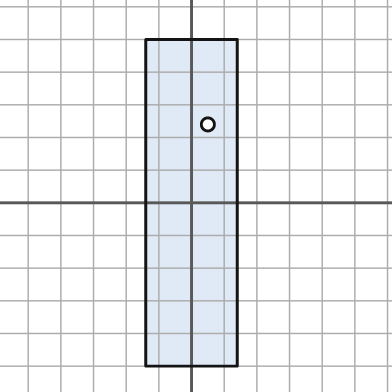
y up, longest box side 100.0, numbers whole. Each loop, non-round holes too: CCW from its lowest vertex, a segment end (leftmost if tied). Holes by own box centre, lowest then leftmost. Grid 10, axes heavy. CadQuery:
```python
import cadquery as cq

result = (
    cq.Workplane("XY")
    .moveTo(-14.0, -50.0)
    .lineTo(14.0, -50.0)
    .lineTo(14.0, 50.0)
    .lineTo(-14.0, 50.0)
    .close()
    .moveTo(5.0, 24.0)
    .circle(2.0)
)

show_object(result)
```